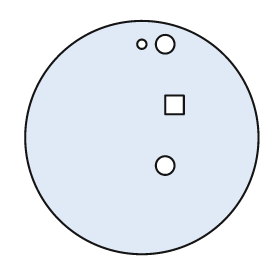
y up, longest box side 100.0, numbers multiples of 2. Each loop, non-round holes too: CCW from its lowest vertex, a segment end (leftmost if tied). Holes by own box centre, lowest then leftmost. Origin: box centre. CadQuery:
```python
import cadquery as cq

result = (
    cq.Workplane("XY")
    .moveTo(0.0, 0.0)
    .circle(50.0)
    .moveTo(10.0, -12.0)
    .circle(4.0)
    .moveTo(10.0, 10.0)
    .lineTo(18.0, 10.0)
    .lineTo(18.0, 18.0)
    .lineTo(10.0, 18.0)
    .close()
    .moveTo(0.0, 40.0)
    .circle(2.0)
    .moveTo(10.0, 40.0)
    .circle(4.0)
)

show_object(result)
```